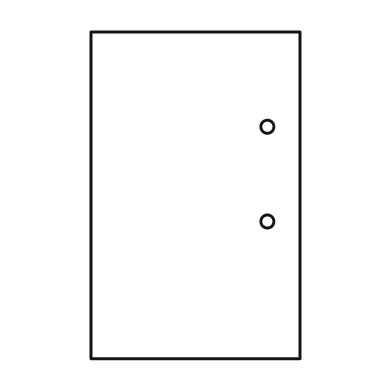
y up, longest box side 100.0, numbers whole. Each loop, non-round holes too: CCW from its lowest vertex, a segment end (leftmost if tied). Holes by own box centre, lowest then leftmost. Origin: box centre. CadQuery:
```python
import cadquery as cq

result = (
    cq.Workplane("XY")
    .moveTo(-32.0, -50.0)
    .lineTo(32.0, -50.0)
    .lineTo(32.0, 50.0)
    .lineTo(-32.0, 50.0)
    .close()
    .moveTo(22.0, -8.0)
    .circle(2.0)
    .moveTo(22.0, 21.0)
    .circle(2.0)
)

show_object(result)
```